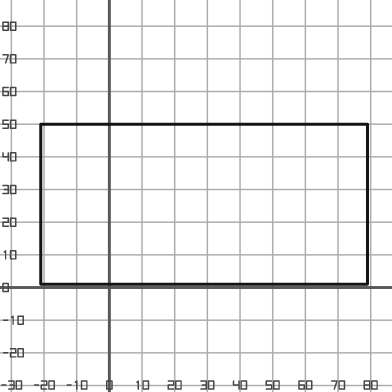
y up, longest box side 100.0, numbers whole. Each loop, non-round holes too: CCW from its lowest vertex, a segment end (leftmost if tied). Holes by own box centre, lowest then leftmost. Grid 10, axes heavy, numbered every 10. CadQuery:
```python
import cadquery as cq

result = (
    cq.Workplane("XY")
    .moveTo(-21.0, 1.0)
    .lineTo(79.0, 1.0)
    .lineTo(79.0, 50.0)
    .lineTo(-21.0, 50.0)
    .close()
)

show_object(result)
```